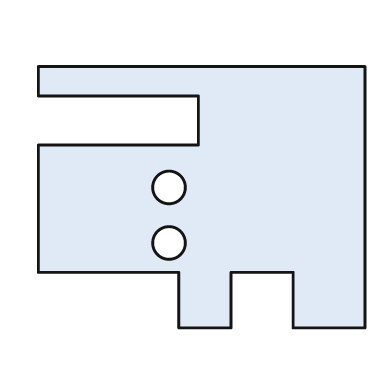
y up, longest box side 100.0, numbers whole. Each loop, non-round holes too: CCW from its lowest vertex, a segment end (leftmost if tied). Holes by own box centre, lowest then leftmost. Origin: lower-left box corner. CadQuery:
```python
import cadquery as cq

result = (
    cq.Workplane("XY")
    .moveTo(43.0, 0.0)
    .lineTo(59.0, 0.0)
    .lineTo(59.0, 17.0)
    .lineTo(78.0, 17.0)
    .lineTo(78.0, 0.0)
    .lineTo(100.0, 0.0)
    .lineTo(100.0, 80.0)
    .lineTo(0.0, 80.0)
    .lineTo(0.0, 71.0)
    .lineTo(49.0, 71.0)
    .lineTo(49.0, 56.0)
    .lineTo(0.0, 56.0)
    .lineTo(0.0, 17.0)
    .lineTo(43.0, 17.0)
    .close()
    .moveTo(40.0, 26.0)
    .circle(5.0)
    .moveTo(40.0, 43.0)
    .circle(5.0)
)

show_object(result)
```